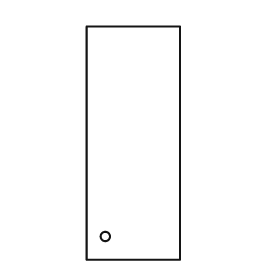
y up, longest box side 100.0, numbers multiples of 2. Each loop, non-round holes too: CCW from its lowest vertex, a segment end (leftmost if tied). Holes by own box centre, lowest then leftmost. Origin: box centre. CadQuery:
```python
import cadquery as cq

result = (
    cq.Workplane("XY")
    .moveTo(-20.0, -50.0)
    .lineTo(20.0, -50.0)
    .lineTo(20.0, 50.0)
    .lineTo(-20.0, 50.0)
    .close()
    .moveTo(-12.0, -40.0)
    .circle(2.0)
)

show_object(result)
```